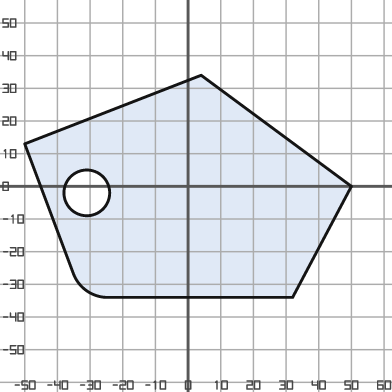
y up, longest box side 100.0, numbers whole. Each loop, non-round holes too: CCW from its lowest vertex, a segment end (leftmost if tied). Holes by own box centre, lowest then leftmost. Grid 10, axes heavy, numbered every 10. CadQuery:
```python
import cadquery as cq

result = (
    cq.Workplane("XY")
    .moveTo(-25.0, -34.0)
    .lineTo(32.0, -34.0)
    .lineTo(50.0, 0.0)
    .lineTo(4.0, 34.0)
    .lineTo(-50.0, 13.0)
    .lineTo(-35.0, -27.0)
    .threePointArc((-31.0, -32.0), (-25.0, -34.0))
    .close()
    .moveTo(-31.0, -2.0)
    .circle(7.0)
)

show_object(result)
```